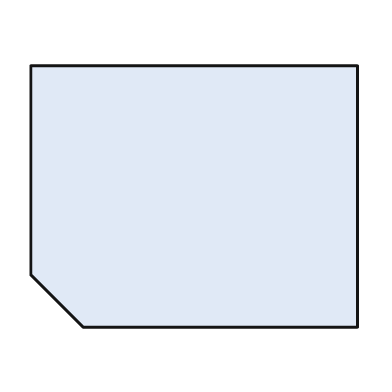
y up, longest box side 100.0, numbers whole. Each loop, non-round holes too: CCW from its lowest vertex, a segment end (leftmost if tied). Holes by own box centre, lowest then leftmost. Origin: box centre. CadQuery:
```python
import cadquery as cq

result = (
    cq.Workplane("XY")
    .moveTo(-34.0, -40.0)
    .lineTo(50.0, -40.0)
    .lineTo(50.0, 40.0)
    .lineTo(-50.0, 40.0)
    .lineTo(-50.0, -24.0)
    .close()
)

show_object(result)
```